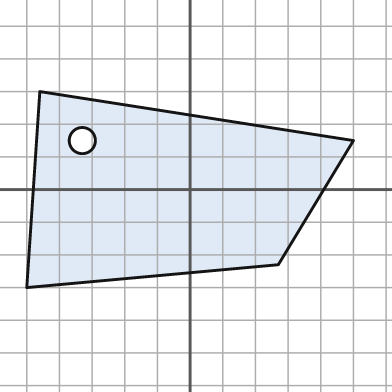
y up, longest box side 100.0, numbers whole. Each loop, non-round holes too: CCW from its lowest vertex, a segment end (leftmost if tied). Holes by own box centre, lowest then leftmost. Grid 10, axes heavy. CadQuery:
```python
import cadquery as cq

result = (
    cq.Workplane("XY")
    .moveTo(-50.0, -30.0)
    .lineTo(27.0, -23.0)
    .lineTo(50.0, 15.0)
    .lineTo(-46.0, 30.0)
    .close()
    .moveTo(-33.0, 15.0)
    .circle(4.0)
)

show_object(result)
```